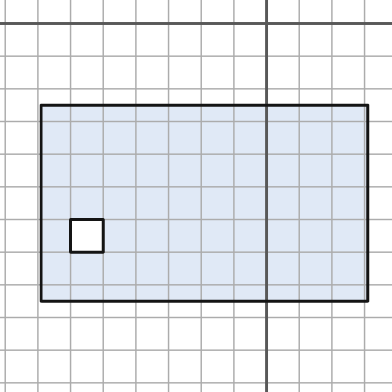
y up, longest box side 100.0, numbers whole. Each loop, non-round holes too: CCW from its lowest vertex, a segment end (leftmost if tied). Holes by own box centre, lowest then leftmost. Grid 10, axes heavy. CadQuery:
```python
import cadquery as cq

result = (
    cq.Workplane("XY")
    .moveTo(-69.0, -85.0)
    .lineTo(31.0, -85.0)
    .lineTo(31.0, -25.0)
    .lineTo(-69.0, -25.0)
    .close()
    .moveTo(-60.0, -70.0)
    .lineTo(-50.0, -70.0)
    .lineTo(-50.0, -60.0)
    .lineTo(-60.0, -60.0)
    .close()
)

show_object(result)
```